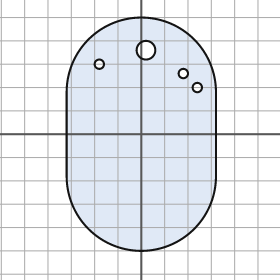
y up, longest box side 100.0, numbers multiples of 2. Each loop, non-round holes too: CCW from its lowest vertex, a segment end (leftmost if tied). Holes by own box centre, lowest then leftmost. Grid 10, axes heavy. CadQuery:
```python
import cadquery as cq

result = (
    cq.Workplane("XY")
    .moveTo(-32.0, -18.0)
    .threePointArc((0.0, -50.0), (32.0, -18.0))
    .lineTo(32.0, 18.0)
    .threePointArc((0.0, 50.0), (-32.0, 18.0))
    .close()
    .moveTo(24.0, 20.0)
    .circle(2.0)
    .moveTo(18.0, 26.0)
    .circle(2.0)
    .moveTo(-18.0, 30.0)
    .circle(2.0)
    .moveTo(2.0, 36.0)
    .circle(4.0)
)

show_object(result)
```